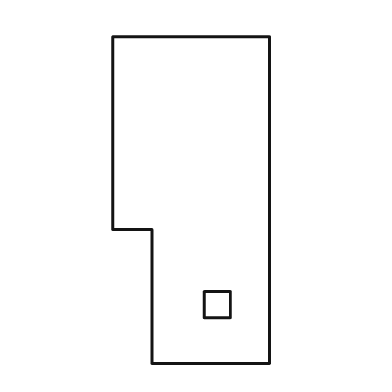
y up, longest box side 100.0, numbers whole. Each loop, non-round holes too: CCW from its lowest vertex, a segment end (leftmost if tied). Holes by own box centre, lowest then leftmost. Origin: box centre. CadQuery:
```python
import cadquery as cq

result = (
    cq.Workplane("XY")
    .moveTo(-12.0, -50.0)
    .lineTo(24.0, -50.0)
    .lineTo(24.0, 50.0)
    .lineTo(-24.0, 50.0)
    .lineTo(-24.0, -9.0)
    .lineTo(-12.0, -9.0)
    .close()
    .moveTo(4.0, -36.0)
    .lineTo(12.0, -36.0)
    .lineTo(12.0, -28.0)
    .lineTo(4.0, -28.0)
    .close()
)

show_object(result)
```